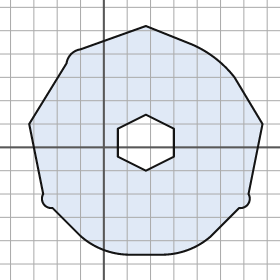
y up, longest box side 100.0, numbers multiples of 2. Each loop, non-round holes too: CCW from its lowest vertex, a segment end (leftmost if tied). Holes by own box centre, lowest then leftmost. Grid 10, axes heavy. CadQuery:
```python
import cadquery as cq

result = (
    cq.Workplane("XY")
    .moveTo(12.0, -46.0)
    .lineTo(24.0, -46.0)
    .threePointArc((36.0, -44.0), (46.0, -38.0))
    .lineTo(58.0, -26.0)
    .threePointArc((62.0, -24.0), (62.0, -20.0))
    .lineTo(68.0, 10.0)
    .lineTo(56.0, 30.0)
    .threePointArc((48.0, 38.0), (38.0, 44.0))
    .lineTo(18.0, 52.0)
    .lineTo(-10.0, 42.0)
    .threePointArc((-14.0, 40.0), (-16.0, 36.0))
    .lineTo(-32.0, 10.0)
    .lineTo(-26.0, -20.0)
    .threePointArc((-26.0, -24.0), (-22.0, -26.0))
    .lineTo(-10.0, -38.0)
    .threePointArc((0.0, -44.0), (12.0, -46.0))
    .close()
    .moveTo(18.0, -10.0)
    .lineTo(30.0, -4.0)
    .lineTo(30.0, 8.0)
    .lineTo(18.0, 14.0)
    .lineTo(6.0, 8.0)
    .lineTo(6.0, -4.0)
    .close()
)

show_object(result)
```